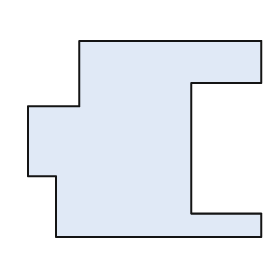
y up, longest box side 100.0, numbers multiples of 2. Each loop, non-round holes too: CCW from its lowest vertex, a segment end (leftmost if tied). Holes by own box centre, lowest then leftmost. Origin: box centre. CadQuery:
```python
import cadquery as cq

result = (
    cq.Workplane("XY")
    .moveTo(-38.0, -42.0)
    .lineTo(50.0, -42.0)
    .lineTo(50.0, -32.0)
    .lineTo(20.0, -32.0)
    .lineTo(20.0, 24.0)
    .lineTo(50.0, 24.0)
    .lineTo(50.0, 42.0)
    .lineTo(-28.0, 42.0)
    .lineTo(-28.0, 14.0)
    .lineTo(-50.0, 14.0)
    .lineTo(-50.0, -16.0)
    .lineTo(-38.0, -16.0)
    .close()
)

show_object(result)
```